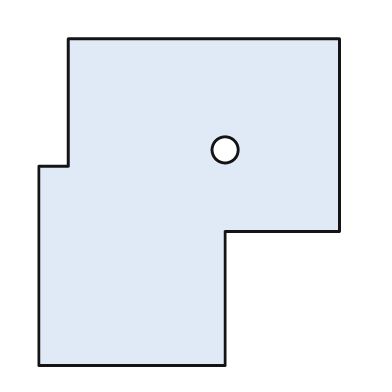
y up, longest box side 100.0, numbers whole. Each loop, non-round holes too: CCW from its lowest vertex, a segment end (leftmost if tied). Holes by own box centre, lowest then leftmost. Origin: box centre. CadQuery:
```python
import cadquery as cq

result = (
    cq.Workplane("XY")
    .moveTo(-46.0, -50.0)
    .lineTo(11.0, -50.0)
    .lineTo(11.0, -9.0)
    .lineTo(46.0, -9.0)
    .lineTo(46.0, 50.0)
    .lineTo(-37.0, 50.0)
    .lineTo(-37.0, 11.0)
    .lineTo(-46.0, 11.0)
    .close()
    .moveTo(11.0, 16.0)
    .circle(4.0)
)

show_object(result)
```